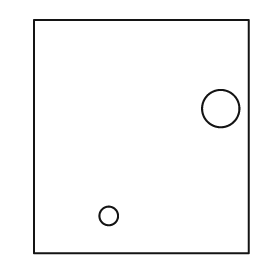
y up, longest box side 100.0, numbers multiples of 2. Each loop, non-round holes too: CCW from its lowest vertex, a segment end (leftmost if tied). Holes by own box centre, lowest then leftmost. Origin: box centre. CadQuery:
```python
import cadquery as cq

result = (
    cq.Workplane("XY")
    .moveTo(-46.0, -50.0)
    .lineTo(46.0, -50.0)
    .lineTo(46.0, 50.0)
    .lineTo(-46.0, 50.0)
    .close()
    .moveTo(-14.0, -34.0)
    .circle(4.0)
    .moveTo(34.0, 12.0)
    .circle(8.0)
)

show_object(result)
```